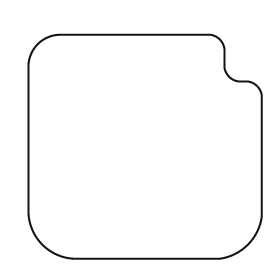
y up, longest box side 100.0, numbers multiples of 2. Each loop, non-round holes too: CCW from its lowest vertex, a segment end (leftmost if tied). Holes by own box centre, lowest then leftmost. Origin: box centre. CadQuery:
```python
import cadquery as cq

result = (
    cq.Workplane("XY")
    .moveTo(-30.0, -48.0)
    .lineTo(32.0, -48.0)
    .threePointArc((44.0, -42.0), (50.0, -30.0))
    .lineTo(50.0, 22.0)
    .threePointArc((48.0, 26.0), (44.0, 28.0))
    .lineTo(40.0, 28.0)
    .threePointArc((36.0, 30.0), (34.0, 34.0))
    .lineTo(34.0, 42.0)
    .threePointArc((32.0, 46.0), (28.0, 48.0))
    .lineTo(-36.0, 48.0)
    .threePointArc((-46.0, 44.0), (-50.0, 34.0))
    .lineTo(-50.0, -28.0)
    .threePointArc((-44.0, -42.0), (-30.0, -48.0))
    .close()
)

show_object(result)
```